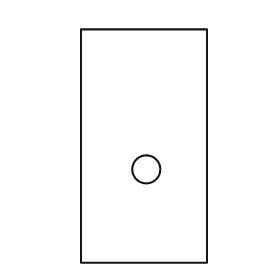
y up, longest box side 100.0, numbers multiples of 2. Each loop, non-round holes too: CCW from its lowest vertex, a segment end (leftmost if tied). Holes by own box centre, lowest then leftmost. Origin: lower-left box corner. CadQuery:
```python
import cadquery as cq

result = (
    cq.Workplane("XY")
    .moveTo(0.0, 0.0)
    .lineTo(54.0, 0.0)
    .lineTo(54.0, 100.0)
    .lineTo(0.0, 100.0)
    .close()
    .moveTo(28.0, 40.0)
    .circle(6.0)
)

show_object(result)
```